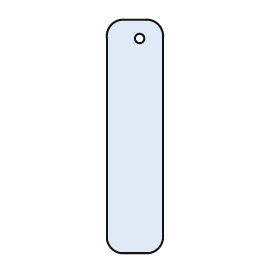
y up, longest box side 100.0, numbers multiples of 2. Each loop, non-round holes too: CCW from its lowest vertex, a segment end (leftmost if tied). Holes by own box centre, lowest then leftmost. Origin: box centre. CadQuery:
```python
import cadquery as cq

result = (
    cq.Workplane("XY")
    .moveTo(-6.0, -50.0)
    .lineTo(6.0, -50.0)
    .threePointArc((10.0, -48.0), (12.0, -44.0))
    .lineTo(12.0, 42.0)
    .threePointArc((10.0, 48.0), (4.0, 50.0))
    .lineTo(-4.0, 50.0)
    .threePointArc((-10.0, 48.0), (-12.0, 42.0))
    .lineTo(-12.0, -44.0)
    .threePointArc((-10.0, -48.0), (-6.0, -50.0))
    .close()
    .moveTo(2.0, 42.0)
    .circle(2.0)
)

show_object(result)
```